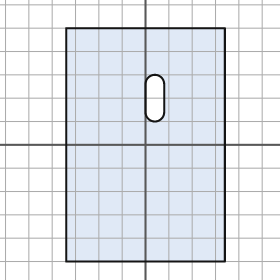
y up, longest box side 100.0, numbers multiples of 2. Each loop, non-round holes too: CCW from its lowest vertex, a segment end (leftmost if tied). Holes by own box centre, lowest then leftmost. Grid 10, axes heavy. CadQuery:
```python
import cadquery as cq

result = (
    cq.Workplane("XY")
    .moveTo(-34.0, -50.0)
    .lineTo(34.0, -50.0)
    .lineTo(34.0, 50.0)
    .lineTo(-34.0, 50.0)
    .close()
    .moveTo(0.0, 14.0)
    .threePointArc((4.0, 10.0), (8.0, 14.0))
    .lineTo(8.0, 26.0)
    .threePointArc((4.0, 30.0), (0.0, 26.0))
    .close()
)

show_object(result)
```